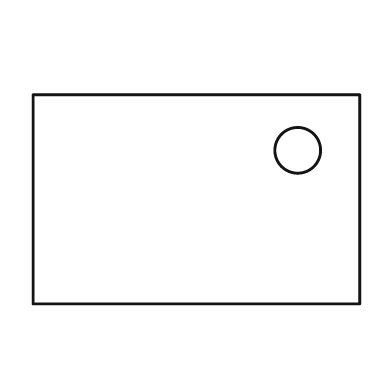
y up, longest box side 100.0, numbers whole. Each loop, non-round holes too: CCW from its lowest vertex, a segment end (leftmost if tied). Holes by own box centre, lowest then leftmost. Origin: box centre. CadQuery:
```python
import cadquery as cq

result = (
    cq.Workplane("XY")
    .moveTo(-50.0, -32.0)
    .lineTo(50.0, -32.0)
    .lineTo(50.0, 32.0)
    .lineTo(-50.0, 32.0)
    .close()
    .moveTo(31.0, 15.0)
    .circle(7.0)
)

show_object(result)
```